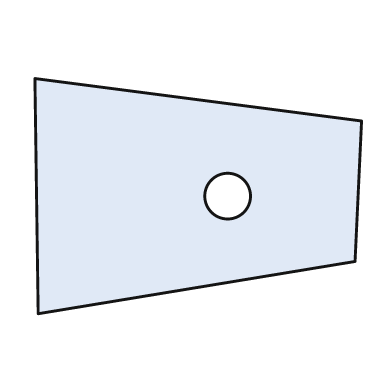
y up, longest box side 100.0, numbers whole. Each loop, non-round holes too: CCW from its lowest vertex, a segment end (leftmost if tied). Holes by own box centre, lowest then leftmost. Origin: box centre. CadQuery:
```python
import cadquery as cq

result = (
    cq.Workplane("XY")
    .moveTo(-49.0, -36.0)
    .lineTo(48.0, -20.0)
    .lineTo(50.0, 23.0)
    .lineTo(-50.0, 36.0)
    .close()
    .moveTo(9.0, 0.0)
    .circle(7.0)
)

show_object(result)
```